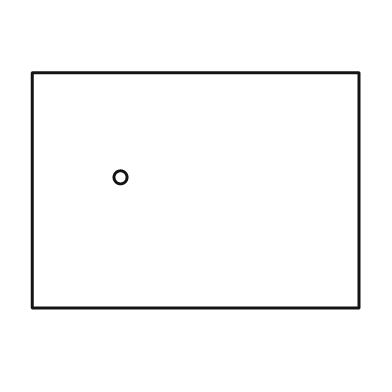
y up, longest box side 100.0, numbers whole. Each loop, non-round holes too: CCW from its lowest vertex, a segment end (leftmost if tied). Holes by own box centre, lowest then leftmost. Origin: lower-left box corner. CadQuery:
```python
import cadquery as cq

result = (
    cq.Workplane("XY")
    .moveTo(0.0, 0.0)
    .lineTo(100.0, 0.0)
    .lineTo(100.0, 72.0)
    .lineTo(0.0, 72.0)
    .close()
    .moveTo(27.0, 40.0)
    .circle(2.0)
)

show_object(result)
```